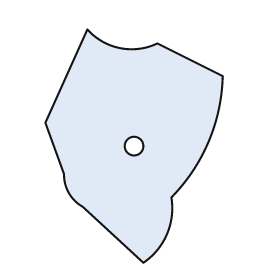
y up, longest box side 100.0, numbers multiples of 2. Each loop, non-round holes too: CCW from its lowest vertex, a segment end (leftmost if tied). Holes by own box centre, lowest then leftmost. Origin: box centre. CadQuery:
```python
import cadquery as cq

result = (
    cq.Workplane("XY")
    .moveTo(4.0, -50.0)
    .threePointArc((14.0, -38.0), (16.0, -22.0))
    .threePointArc((32.0, 2.0), (38.0, 30.0))
    .lineTo(10.0, 44.0)
    .threePointArc((-6.0, 42.0), (-20.0, 50.0))
    .lineTo(-38.0, 10.0)
    .lineTo(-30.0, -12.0)
    .threePointArc((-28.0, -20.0), (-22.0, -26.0))
    .close()
    .moveTo(0.0, 0.0)
    .circle(4.0)
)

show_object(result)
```